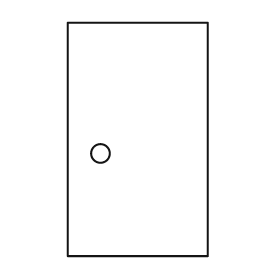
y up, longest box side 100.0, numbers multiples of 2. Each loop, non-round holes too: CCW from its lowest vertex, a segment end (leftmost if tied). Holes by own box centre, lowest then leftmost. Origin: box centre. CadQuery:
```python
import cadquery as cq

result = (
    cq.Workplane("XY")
    .moveTo(-30.0, -50.0)
    .lineTo(30.0, -50.0)
    .lineTo(30.0, 50.0)
    .lineTo(-30.0, 50.0)
    .close()
    .moveTo(-16.0, -6.0)
    .circle(4.0)
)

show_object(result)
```